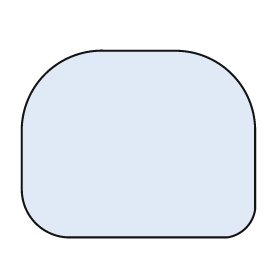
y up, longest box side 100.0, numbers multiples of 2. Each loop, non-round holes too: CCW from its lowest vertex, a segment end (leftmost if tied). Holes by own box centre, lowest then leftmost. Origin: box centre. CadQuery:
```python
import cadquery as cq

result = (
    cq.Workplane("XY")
    .moveTo(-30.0, -40.0)
    .lineTo(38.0, -40.0)
    .threePointArc((46.0, -36.0), (50.0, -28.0))
    .lineTo(50.0, 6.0)
    .threePointArc((40.0, 30.0), (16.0, 40.0))
    .lineTo(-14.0, 40.0)
    .threePointArc((-40.0, 30.0), (-50.0, 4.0))
    .lineTo(-50.0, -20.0)
    .threePointArc((-44.0, -34.0), (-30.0, -40.0))
    .close()
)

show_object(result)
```